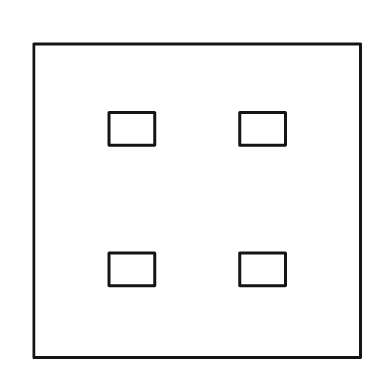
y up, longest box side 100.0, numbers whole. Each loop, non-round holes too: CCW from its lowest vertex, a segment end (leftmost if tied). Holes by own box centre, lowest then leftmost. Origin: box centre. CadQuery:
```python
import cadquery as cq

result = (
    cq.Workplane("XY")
    .moveTo(-50.0, -48.0)
    .lineTo(50.0, -48.0)
    .lineTo(50.0, 48.0)
    .lineTo(-50.0, 48.0)
    .close()
    .moveTo(-27.0, -26.0)
    .lineTo(-13.0, -26.0)
    .lineTo(-13.0, -16.0)
    .lineTo(-27.0, -16.0)
    .close()
    .moveTo(13.0, -26.0)
    .lineTo(27.0, -26.0)
    .lineTo(27.0, -16.0)
    .lineTo(13.0, -16.0)
    .close()
    .moveTo(-27.0, 17.0)
    .lineTo(-13.0, 17.0)
    .lineTo(-13.0, 27.0)
    .lineTo(-27.0, 27.0)
    .close()
    .moveTo(13.0, 17.0)
    .lineTo(27.0, 17.0)
    .lineTo(27.0, 27.0)
    .lineTo(13.0, 27.0)
    .close()
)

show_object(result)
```